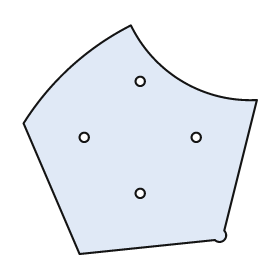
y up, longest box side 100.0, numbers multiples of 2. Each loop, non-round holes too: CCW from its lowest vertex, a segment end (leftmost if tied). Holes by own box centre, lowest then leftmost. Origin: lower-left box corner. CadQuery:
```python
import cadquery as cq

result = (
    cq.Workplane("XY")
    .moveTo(24.0, 0.0)
    .lineTo(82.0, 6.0)
    .threePointArc((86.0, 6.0), (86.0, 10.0))
    .lineTo(100.0, 66.0)
    .threePointArc((68.0, 74.0), (46.0, 98.0))
    .threePointArc((20.0, 80.0), (0.0, 56.0))
    .close()
    .moveTo(50.0, 26.0)
    .circle(2.0)
    .moveTo(26.0, 50.0)
    .circle(2.0)
    .moveTo(74.0, 50.0)
    .circle(2.0)
    .moveTo(50.0, 74.0)
    .circle(2.0)
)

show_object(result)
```